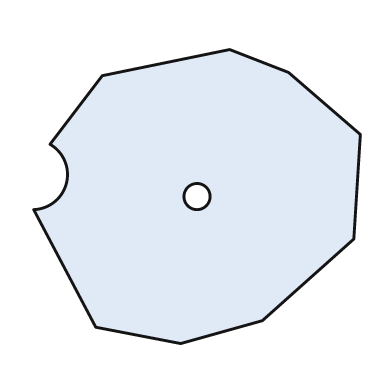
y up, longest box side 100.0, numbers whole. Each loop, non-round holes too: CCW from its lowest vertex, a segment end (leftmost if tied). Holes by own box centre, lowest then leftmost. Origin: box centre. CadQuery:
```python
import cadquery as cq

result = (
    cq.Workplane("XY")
    .moveTo(-5.0, -45.0)
    .lineTo(20.0, -38.0)
    .lineTo(48.0, -13.0)
    .lineTo(50.0, 19.0)
    .lineTo(28.0, 38.0)
    .lineTo(10.0, 45.0)
    .lineTo(-29.0, 37.0)
    .lineTo(-45.0, 16.0)
    .threePointArc((-40.0, 4.0), (-50.0, -4.0))
    .lineTo(-31.0, -40.0)
    .close()
    .moveTo(0.0, 0.0)
    .circle(4.0)
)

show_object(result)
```